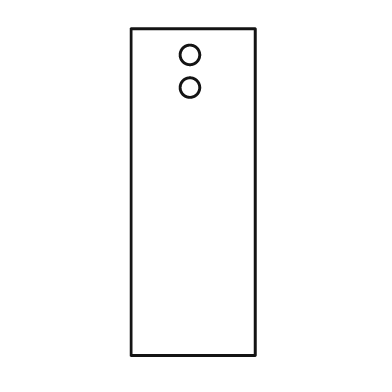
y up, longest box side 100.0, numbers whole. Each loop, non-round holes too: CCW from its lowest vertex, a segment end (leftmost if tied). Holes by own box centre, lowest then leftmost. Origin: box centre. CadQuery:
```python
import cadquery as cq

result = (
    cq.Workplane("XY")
    .moveTo(-19.0, -50.0)
    .lineTo(19.0, -50.0)
    .lineTo(19.0, 50.0)
    .lineTo(-19.0, 50.0)
    .close()
    .moveTo(-1.0, 32.0)
    .circle(3.0)
    .moveTo(-1.0, 42.0)
    .circle(3.0)
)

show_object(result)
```